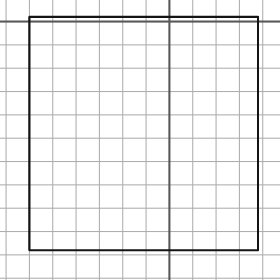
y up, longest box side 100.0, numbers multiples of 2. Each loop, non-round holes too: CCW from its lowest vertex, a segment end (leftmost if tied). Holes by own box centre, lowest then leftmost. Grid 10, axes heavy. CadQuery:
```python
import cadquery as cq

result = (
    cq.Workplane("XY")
    .moveTo(-60.0, -98.0)
    .lineTo(38.0, -98.0)
    .lineTo(38.0, 2.0)
    .lineTo(-60.0, 2.0)
    .close()
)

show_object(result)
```